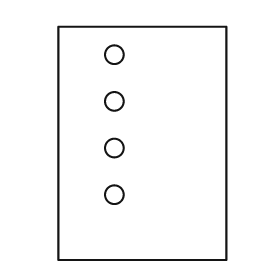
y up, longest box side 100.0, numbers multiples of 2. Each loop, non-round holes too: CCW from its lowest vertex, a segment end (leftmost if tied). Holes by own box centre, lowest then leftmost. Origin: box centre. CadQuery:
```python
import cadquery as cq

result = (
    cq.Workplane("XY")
    .moveTo(-36.0, -50.0)
    .lineTo(36.0, -50.0)
    .lineTo(36.0, 50.0)
    .lineTo(-36.0, 50.0)
    .close()
    .moveTo(-12.0, -22.0)
    .circle(4.0)
    .moveTo(-12.0, -2.0)
    .circle(4.0)
    .moveTo(-12.0, 18.0)
    .circle(4.0)
    .moveTo(-12.0, 38.0)
    .circle(4.0)
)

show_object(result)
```